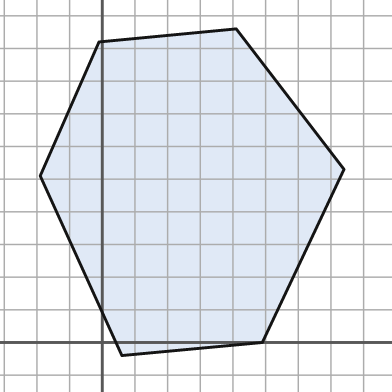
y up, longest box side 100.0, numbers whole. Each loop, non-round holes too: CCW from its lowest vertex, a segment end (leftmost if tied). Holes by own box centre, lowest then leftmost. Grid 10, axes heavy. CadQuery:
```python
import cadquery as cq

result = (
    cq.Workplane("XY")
    .moveTo(6.0, -4.0)
    .lineTo(49.0, 0.0)
    .lineTo(74.0, 53.0)
    .lineTo(41.0, 96.0)
    .lineTo(-1.0, 92.0)
    .lineTo(-19.0, 51.0)
    .close()
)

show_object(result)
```